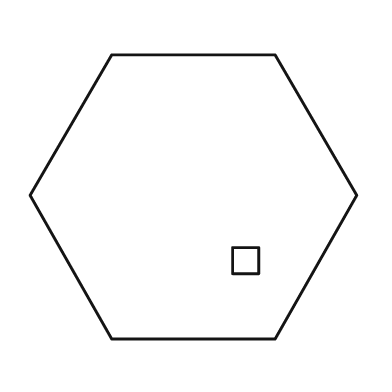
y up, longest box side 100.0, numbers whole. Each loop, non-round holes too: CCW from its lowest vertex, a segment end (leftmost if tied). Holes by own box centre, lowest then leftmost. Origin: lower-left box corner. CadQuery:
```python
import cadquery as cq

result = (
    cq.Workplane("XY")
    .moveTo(25.0, 0.0)
    .lineTo(75.0, 0.0)
    .lineTo(100.0, 44.0)
    .lineTo(75.0, 87.0)
    .lineTo(25.0, 87.0)
    .lineTo(0.0, 44.0)
    .close()
    .moveTo(62.0, 20.0)
    .lineTo(70.0, 20.0)
    .lineTo(70.0, 28.0)
    .lineTo(62.0, 28.0)
    .close()
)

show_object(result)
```